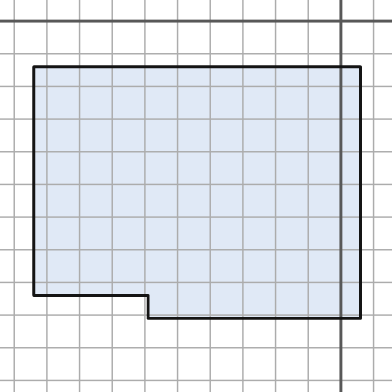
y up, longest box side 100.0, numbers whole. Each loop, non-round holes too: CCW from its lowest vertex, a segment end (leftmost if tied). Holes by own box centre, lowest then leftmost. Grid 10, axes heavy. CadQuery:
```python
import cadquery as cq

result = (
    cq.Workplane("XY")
    .moveTo(-59.0, -91.0)
    .lineTo(6.0, -91.0)
    .lineTo(6.0, -14.0)
    .lineTo(-94.0, -14.0)
    .lineTo(-94.0, -84.0)
    .lineTo(-59.0, -84.0)
    .close()
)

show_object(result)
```